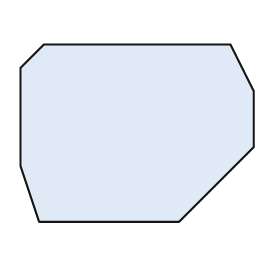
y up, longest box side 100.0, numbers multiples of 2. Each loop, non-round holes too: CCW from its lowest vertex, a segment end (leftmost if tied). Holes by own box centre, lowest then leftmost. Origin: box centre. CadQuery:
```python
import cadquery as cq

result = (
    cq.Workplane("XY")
    .moveTo(-42.0, -38.0)
    .lineTo(18.0, -38.0)
    .lineTo(50.0, -6.0)
    .lineTo(50.0, 18.0)
    .lineTo(40.0, 38.0)
    .lineTo(-40.0, 38.0)
    .lineTo(-50.0, 28.0)
    .lineTo(-50.0, -14.0)
    .close()
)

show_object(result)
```